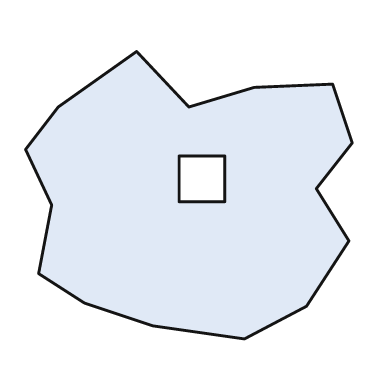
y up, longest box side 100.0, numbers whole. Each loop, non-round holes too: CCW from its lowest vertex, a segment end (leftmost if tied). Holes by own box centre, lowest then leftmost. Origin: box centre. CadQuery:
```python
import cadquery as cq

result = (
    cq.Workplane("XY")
    .moveTo(17.0, -44.0)
    .lineTo(36.0, -34.0)
    .lineTo(49.0, -14.0)
    .lineTo(39.0, 2.0)
    .lineTo(50.0, 16.0)
    .lineTo(44.0, 34.0)
    .lineTo(20.0, 33.0)
    .lineTo(0.0, 27.0)
    .lineTo(-16.0, 44.0)
    .lineTo(-40.0, 27.0)
    .lineTo(-50.0, 14.0)
    .lineTo(-42.0, -3.0)
    .lineTo(-46.0, -24.0)
    .lineTo(-32.0, -33.0)
    .lineTo(-11.0, -40.0)
    .close()
    .moveTo(-3.0, -2.0)
    .lineTo(11.0, -2.0)
    .lineTo(11.0, 12.0)
    .lineTo(-3.0, 12.0)
    .close()
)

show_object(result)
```